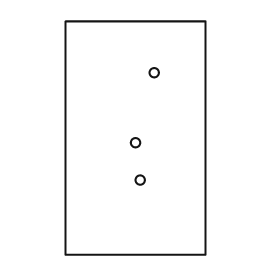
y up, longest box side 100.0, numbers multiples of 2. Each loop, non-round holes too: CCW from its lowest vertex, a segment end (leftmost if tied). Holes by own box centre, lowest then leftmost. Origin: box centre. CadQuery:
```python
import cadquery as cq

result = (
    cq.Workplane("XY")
    .moveTo(-30.0, -50.0)
    .lineTo(30.0, -50.0)
    .lineTo(30.0, 50.0)
    .lineTo(-30.0, 50.0)
    .close()
    .moveTo(2.0, -18.0)
    .circle(2.0)
    .moveTo(0.0, -2.0)
    .circle(2.0)
    .moveTo(8.0, 28.0)
    .circle(2.0)
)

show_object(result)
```